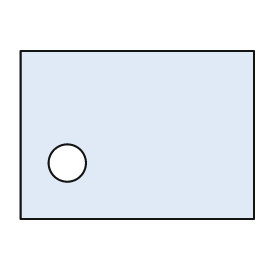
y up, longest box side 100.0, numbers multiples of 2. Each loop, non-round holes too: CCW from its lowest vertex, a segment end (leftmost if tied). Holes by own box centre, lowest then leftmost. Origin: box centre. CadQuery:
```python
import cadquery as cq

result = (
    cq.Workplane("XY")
    .moveTo(-50.0, -36.0)
    .lineTo(50.0, -36.0)
    .lineTo(50.0, 36.0)
    .lineTo(-50.0, 36.0)
    .close()
    .moveTo(-30.0, -12.0)
    .circle(8.0)
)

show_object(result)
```